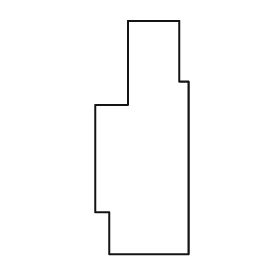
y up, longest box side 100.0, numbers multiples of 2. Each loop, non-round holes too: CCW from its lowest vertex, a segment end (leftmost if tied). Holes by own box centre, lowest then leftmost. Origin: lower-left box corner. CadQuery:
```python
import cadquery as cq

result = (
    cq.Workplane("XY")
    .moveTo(6.0, 0.0)
    .lineTo(40.0, 0.0)
    .lineTo(40.0, 74.0)
    .lineTo(36.0, 74.0)
    .lineTo(36.0, 100.0)
    .lineTo(14.0, 100.0)
    .lineTo(14.0, 64.0)
    .lineTo(0.0, 64.0)
    .lineTo(0.0, 18.0)
    .lineTo(6.0, 18.0)
    .close()
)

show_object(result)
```